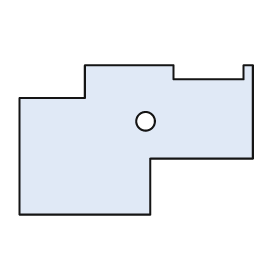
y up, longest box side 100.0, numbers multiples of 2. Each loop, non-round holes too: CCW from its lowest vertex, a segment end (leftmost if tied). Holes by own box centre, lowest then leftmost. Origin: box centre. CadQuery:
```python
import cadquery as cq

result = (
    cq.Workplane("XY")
    .moveTo(-50.0, -32.0)
    .lineTo(6.0, -32.0)
    .lineTo(6.0, -8.0)
    .lineTo(50.0, -8.0)
    .lineTo(50.0, 32.0)
    .lineTo(46.0, 32.0)
    .lineTo(46.0, 26.0)
    .lineTo(16.0, 26.0)
    .lineTo(16.0, 32.0)
    .lineTo(-22.0, 32.0)
    .lineTo(-22.0, 18.0)
    .lineTo(-50.0, 18.0)
    .close()
    .moveTo(4.0, 8.0)
    .circle(4.0)
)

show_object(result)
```